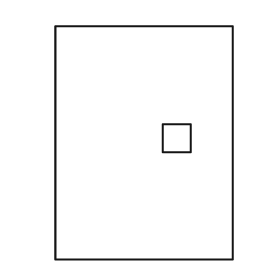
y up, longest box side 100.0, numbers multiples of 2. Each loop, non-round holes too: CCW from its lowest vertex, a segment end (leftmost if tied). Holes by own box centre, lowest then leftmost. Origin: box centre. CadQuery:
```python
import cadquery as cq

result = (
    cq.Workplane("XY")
    .moveTo(-38.0, -50.0)
    .lineTo(38.0, -50.0)
    .lineTo(38.0, 50.0)
    .lineTo(-38.0, 50.0)
    .close()
    .moveTo(8.0, -4.0)
    .lineTo(20.0, -4.0)
    .lineTo(20.0, 8.0)
    .lineTo(8.0, 8.0)
    .close()
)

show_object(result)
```